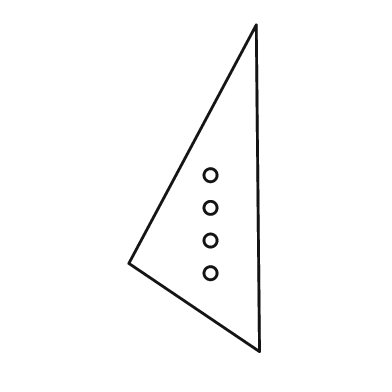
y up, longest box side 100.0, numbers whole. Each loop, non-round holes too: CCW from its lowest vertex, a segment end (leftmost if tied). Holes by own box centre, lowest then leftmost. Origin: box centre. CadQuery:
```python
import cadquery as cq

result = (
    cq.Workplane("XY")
    .moveTo(20.0, -50.0)
    .lineTo(19.0, 50.0)
    .lineTo(-20.0, -23.0)
    .close()
    .moveTo(5.0, -26.0)
    .circle(2.0)
    .moveTo(5.0, -16.0)
    .circle(2.0)
    .moveTo(5.0, -6.0)
    .circle(2.0)
    .moveTo(5.0, 4.0)
    .circle(2.0)
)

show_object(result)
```